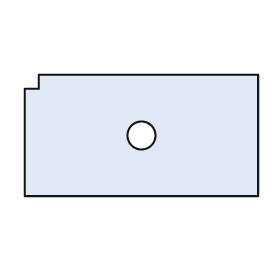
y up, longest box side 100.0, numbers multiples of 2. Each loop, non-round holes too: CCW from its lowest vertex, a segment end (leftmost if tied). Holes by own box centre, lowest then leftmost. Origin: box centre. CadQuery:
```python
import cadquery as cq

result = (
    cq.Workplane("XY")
    .moveTo(-50.0, -26.0)
    .lineTo(50.0, -26.0)
    .lineTo(50.0, 26.0)
    .lineTo(-44.0, 26.0)
    .lineTo(-44.0, 20.0)
    .lineTo(-50.0, 20.0)
    .close()
    .moveTo(0.0, 0.0)
    .circle(6.0)
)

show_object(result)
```